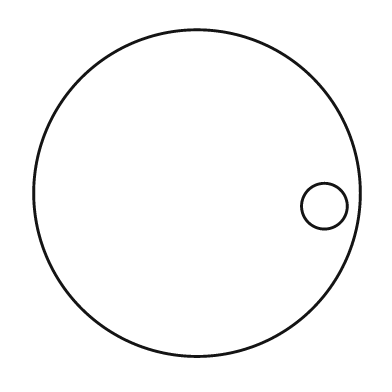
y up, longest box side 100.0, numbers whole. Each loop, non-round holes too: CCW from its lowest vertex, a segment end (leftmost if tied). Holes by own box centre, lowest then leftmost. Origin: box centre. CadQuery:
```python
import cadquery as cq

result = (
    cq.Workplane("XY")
    .moveTo(0.0, 0.0)
    .circle(50.0)
    .moveTo(39.0, -4.0)
    .circle(7.0)
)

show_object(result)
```